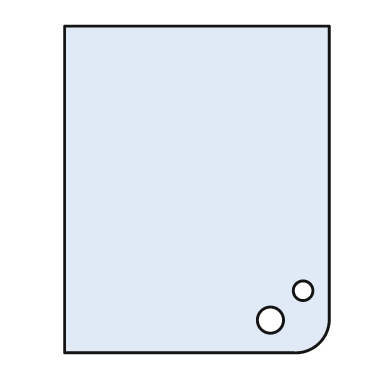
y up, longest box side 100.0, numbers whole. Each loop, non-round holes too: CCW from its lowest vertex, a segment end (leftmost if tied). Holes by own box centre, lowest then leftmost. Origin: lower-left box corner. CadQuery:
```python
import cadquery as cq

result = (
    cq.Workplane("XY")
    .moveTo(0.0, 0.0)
    .lineTo(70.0, 0.0)
    .threePointArc((78.0, 3.0), (81.0, 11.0))
    .lineTo(81.0, 100.0)
    .lineTo(0.0, 100.0)
    .close()
    .moveTo(63.0, 10.0)
    .circle(4.0)
    .moveTo(73.0, 19.0)
    .circle(3.0)
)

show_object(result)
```